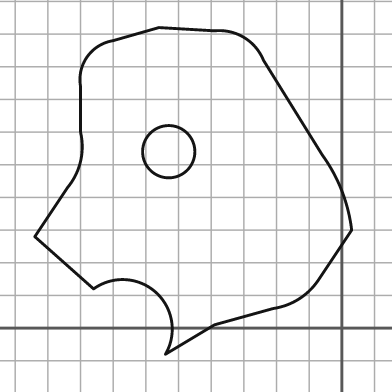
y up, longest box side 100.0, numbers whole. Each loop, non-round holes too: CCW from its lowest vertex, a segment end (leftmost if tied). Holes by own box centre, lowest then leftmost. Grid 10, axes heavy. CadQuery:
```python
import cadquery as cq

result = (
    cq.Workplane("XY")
    .moveTo(-54.0, -8.0)
    .lineTo(-39.0, 1.0)
    .lineTo(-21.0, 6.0)
    .threePointArc((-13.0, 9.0), (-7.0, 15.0))
    .lineTo(3.0, 30.0)
    .threePointArc((0.0, 42.0), (-6.0, 53.0))
    .lineTo(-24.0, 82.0)
    .threePointArc((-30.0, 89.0), (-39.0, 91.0))
    .lineTo(-56.0, 92.0)
    .lineTo(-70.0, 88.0)
    .threePointArc((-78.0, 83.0), (-80.0, 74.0))
    .lineTo(-80.0, 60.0)
    .threePointArc((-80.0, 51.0), (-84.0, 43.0))
    .lineTo(-94.0, 28.0)
    .lineTo(-76.0, 12.0)
    .threePointArc((-57.0, 11.0), (-54.0, -8.0))
    .close()
    .moveTo(-53.0, 54.0)
    .circle(8.0)
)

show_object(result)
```